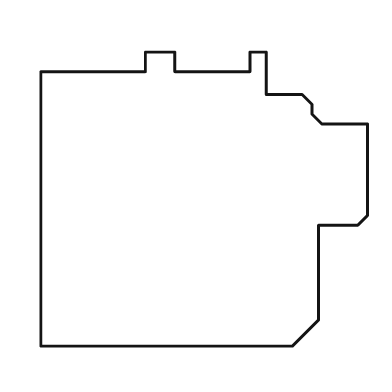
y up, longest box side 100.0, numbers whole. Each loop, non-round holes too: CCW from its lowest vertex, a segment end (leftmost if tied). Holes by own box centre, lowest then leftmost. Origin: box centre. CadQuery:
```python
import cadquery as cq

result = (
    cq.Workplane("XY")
    .moveTo(-50.0, -45.0)
    .lineTo(27.0, -45.0)
    .lineTo(35.0, -37.0)
    .lineTo(35.0, -8.0)
    .lineTo(47.0, -8.0)
    .lineTo(50.0, -5.0)
    .lineTo(50.0, 23.0)
    .lineTo(36.0, 23.0)
    .lineTo(33.0, 26.0)
    .lineTo(33.0, 29.0)
    .lineTo(30.0, 32.0)
    .lineTo(19.0, 32.0)
    .lineTo(19.0, 45.0)
    .lineTo(14.0, 45.0)
    .lineTo(14.0, 39.0)
    .lineTo(-9.0, 39.0)
    .lineTo(-9.0, 45.0)
    .lineTo(-18.0, 45.0)
    .lineTo(-18.0, 39.0)
    .lineTo(-50.0, 39.0)
    .close()
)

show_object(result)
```